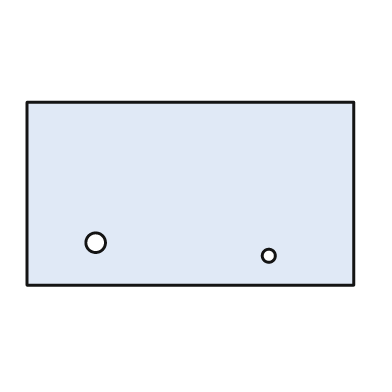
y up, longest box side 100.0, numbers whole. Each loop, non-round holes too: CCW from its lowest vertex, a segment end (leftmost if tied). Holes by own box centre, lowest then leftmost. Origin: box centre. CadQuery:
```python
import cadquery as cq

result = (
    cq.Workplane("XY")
    .moveTo(-50.0, -28.0)
    .lineTo(50.0, -28.0)
    .lineTo(50.0, 28.0)
    .lineTo(-50.0, 28.0)
    .close()
    .moveTo(24.0, -19.0)
    .circle(2.0)
    .moveTo(-29.0, -15.0)
    .circle(3.0)
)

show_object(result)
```